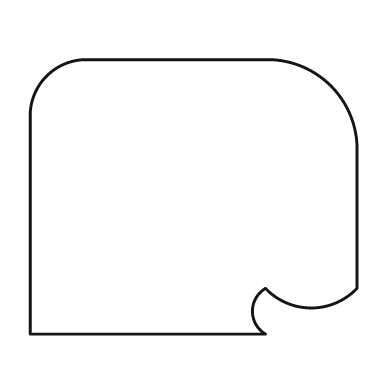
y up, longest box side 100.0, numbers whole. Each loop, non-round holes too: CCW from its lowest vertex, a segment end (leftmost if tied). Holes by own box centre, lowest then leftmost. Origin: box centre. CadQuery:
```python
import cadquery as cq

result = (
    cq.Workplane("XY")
    .moveTo(-50.0, -42.0)
    .lineTo(22.0, -42.0)
    .threePointArc((18.0, -35.0), (22.0, -28.0))
    .threePointArc((36.0, -34.0), (50.0, -28.0))
    .lineTo(50.0, 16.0)
    .threePointArc((42.0, 34.0), (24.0, 42.0))
    .lineTo(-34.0, 42.0)
    .threePointArc((-45.0, 37.0), (-50.0, 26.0))
    .close()
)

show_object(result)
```